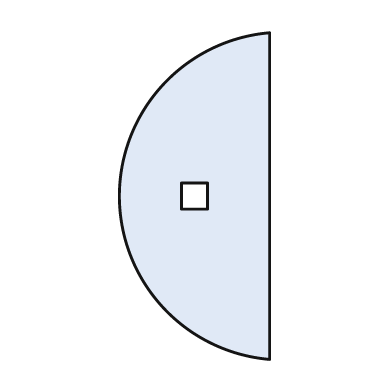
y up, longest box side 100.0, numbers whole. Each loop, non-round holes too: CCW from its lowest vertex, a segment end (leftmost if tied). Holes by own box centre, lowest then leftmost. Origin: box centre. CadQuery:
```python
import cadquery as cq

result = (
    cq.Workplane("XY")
    .moveTo(23.0, -50.0)
    .lineTo(23.0, 50.0)
    .threePointArc((-23.0, 0.0), (23.0, -50.0))
    .close()
    .moveTo(-4.0, -4.0)
    .lineTo(4.0, -4.0)
    .lineTo(4.0, 4.0)
    .lineTo(-4.0, 4.0)
    .close()
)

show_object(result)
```